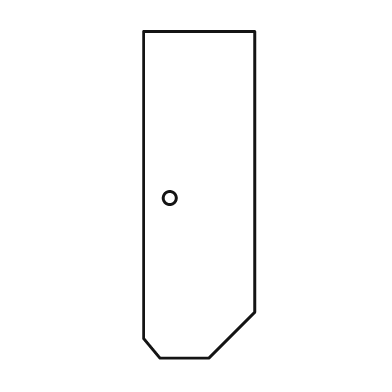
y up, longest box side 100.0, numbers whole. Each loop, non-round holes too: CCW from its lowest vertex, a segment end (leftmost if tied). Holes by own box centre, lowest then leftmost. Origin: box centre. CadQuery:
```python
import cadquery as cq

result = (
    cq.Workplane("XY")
    .moveTo(-12.0, -50.0)
    .lineTo(3.0, -50.0)
    .lineTo(17.0, -36.0)
    .lineTo(17.0, 50.0)
    .lineTo(-17.0, 50.0)
    .lineTo(-17.0, -44.0)
    .close()
    .moveTo(-9.0, -1.0)
    .circle(2.0)
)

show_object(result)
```